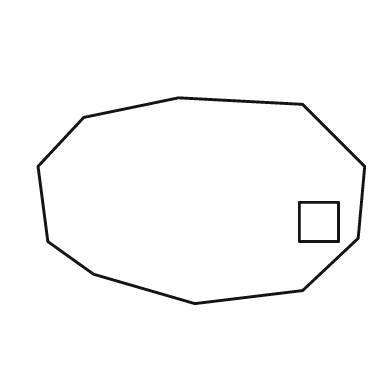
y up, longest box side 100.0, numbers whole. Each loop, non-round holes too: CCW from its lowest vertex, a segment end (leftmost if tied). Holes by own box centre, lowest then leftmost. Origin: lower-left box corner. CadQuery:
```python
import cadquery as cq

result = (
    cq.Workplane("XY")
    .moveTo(48.0, 0.0)
    .lineTo(81.0, 4.0)
    .lineTo(98.0, 20.0)
    .lineTo(100.0, 42.0)
    .lineTo(81.0, 61.0)
    .lineTo(43.0, 63.0)
    .lineTo(14.0, 57.0)
    .lineTo(0.0, 42.0)
    .lineTo(3.0, 19.0)
    .lineTo(17.0, 9.0)
    .close()
    .moveTo(80.0, 19.0)
    .lineTo(92.0, 19.0)
    .lineTo(92.0, 31.0)
    .lineTo(80.0, 31.0)
    .close()
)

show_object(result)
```